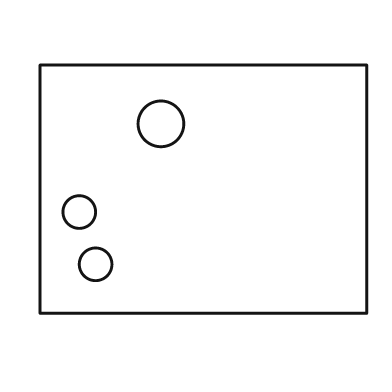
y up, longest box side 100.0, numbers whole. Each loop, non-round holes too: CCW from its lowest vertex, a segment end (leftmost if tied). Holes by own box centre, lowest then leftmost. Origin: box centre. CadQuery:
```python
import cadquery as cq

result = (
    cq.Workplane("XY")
    .moveTo(-50.0, -38.0)
    .lineTo(50.0, -38.0)
    .lineTo(50.0, 38.0)
    .lineTo(-50.0, 38.0)
    .close()
    .moveTo(-33.0, -23.0)
    .circle(5.0)
    .moveTo(-38.0, -7.0)
    .circle(5.0)
    .moveTo(-13.0, 20.0)
    .circle(7.0)
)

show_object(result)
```